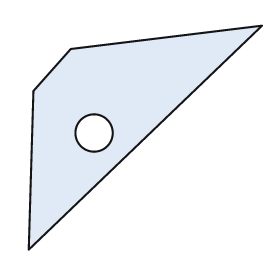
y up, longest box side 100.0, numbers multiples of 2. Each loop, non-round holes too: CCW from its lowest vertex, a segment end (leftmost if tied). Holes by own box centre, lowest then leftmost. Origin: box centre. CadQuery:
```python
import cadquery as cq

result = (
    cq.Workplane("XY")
    .moveTo(-50.0, -48.0)
    .lineTo(50.0, 48.0)
    .lineTo(-32.0, 38.0)
    .lineTo(-48.0, 20.0)
    .close()
    .moveTo(-22.0, 2.0)
    .circle(8.0)
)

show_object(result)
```